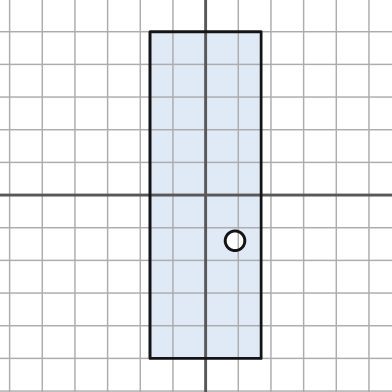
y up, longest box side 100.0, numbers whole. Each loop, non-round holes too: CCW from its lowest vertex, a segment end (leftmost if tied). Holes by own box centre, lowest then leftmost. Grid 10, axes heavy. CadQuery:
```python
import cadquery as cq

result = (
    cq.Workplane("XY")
    .moveTo(-17.0, -50.0)
    .lineTo(17.0, -50.0)
    .lineTo(17.0, 50.0)
    .lineTo(-17.0, 50.0)
    .close()
    .moveTo(9.0, -14.0)
    .circle(3.0)
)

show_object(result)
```